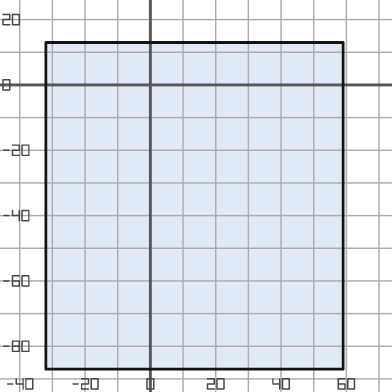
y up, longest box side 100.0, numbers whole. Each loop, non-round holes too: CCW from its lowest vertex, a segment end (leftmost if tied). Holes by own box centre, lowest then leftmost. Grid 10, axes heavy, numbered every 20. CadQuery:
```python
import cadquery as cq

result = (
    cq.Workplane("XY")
    .moveTo(-32.0, -87.0)
    .lineTo(59.0, -87.0)
    .lineTo(59.0, 13.0)
    .lineTo(-32.0, 13.0)
    .close()
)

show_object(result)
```